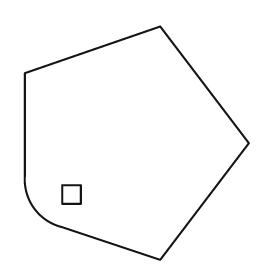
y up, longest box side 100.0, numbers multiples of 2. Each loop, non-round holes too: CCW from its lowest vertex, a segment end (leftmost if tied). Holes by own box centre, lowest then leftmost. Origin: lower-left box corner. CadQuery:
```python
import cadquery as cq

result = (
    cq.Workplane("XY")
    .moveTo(58.0, 0.0)
    .lineTo(96.0, 50.0)
    .lineTo(58.0, 100.0)
    .lineTo(0.0, 80.0)
    .lineTo(0.0, 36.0)
    .threePointArc((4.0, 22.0), (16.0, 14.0))
    .close()
    .moveTo(16.0, 24.0)
    .lineTo(24.0, 24.0)
    .lineTo(24.0, 32.0)
    .lineTo(16.0, 32.0)
    .close()
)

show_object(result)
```